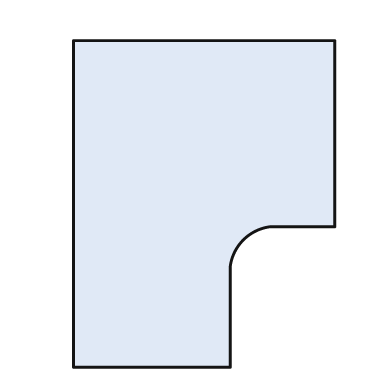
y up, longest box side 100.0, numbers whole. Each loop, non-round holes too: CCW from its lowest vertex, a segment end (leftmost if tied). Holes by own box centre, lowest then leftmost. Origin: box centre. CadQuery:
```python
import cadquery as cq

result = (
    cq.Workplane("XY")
    .moveTo(-40.0, -50.0)
    .lineTo(8.0, -50.0)
    .lineTo(8.0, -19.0)
    .threePointArc((12.0, -11.0), (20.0, -7.0))
    .lineTo(40.0, -7.0)
    .lineTo(40.0, 50.0)
    .lineTo(-40.0, 50.0)
    .close()
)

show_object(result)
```